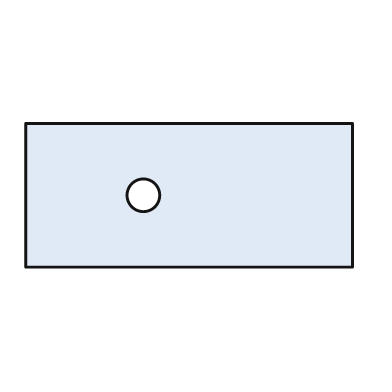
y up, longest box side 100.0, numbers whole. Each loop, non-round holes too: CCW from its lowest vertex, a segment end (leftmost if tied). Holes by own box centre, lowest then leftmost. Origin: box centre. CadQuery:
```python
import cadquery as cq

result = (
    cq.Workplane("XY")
    .moveTo(-50.0, -22.0)
    .lineTo(50.0, -22.0)
    .lineTo(50.0, 22.0)
    .lineTo(-50.0, 22.0)
    .close()
    .moveTo(-14.0, 0.0)
    .circle(5.0)
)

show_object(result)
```